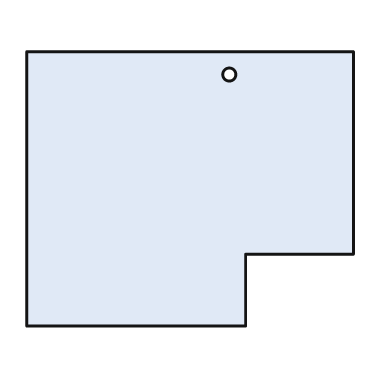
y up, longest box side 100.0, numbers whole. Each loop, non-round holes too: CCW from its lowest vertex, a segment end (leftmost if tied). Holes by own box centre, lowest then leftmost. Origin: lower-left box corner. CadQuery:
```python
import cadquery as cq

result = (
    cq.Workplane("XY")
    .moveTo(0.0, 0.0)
    .lineTo(67.0, 0.0)
    .lineTo(67.0, 22.0)
    .lineTo(100.0, 22.0)
    .lineTo(100.0, 84.0)
    .lineTo(0.0, 84.0)
    .close()
    .moveTo(62.0, 77.0)
    .circle(2.0)
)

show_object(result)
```